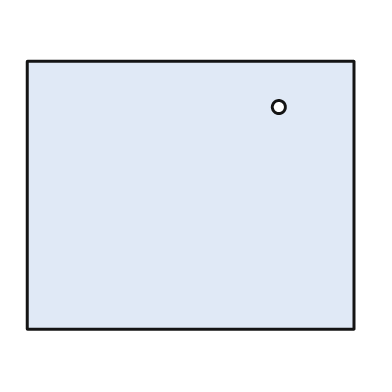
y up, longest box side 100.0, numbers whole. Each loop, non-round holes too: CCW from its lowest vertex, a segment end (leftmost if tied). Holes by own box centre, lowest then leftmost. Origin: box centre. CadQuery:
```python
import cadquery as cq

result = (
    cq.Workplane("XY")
    .moveTo(-50.0, -41.0)
    .lineTo(50.0, -41.0)
    .lineTo(50.0, 41.0)
    .lineTo(-50.0, 41.0)
    .close()
    .moveTo(27.0, 27.0)
    .circle(2.0)
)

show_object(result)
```